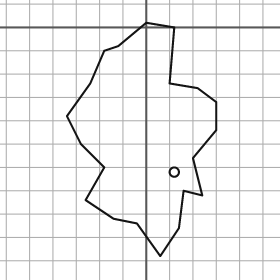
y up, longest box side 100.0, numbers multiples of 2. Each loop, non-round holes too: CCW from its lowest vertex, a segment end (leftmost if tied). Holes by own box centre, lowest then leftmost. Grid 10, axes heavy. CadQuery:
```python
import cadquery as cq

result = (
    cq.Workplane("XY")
    .moveTo(6.0, -98.0)
    .lineTo(14.0, -86.0)
    .lineTo(16.0, -70.0)
    .lineTo(24.0, -72.0)
    .lineTo(20.0, -56.0)
    .lineTo(30.0, -44.0)
    .lineTo(30.0, -32.0)
    .lineTo(22.0, -26.0)
    .lineTo(10.0, -24.0)
    .lineTo(12.0, 0.0)
    .lineTo(0.0, 2.0)
    .lineTo(-12.0, -8.0)
    .lineTo(-18.0, -10.0)
    .lineTo(-24.0, -24.0)
    .lineTo(-34.0, -38.0)
    .lineTo(-28.0, -50.0)
    .lineTo(-18.0, -60.0)
    .lineTo(-26.0, -74.0)
    .lineTo(-14.0, -82.0)
    .lineTo(-4.0, -84.0)
    .close()
    .moveTo(12.0, -62.0)
    .circle(2.0)
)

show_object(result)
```